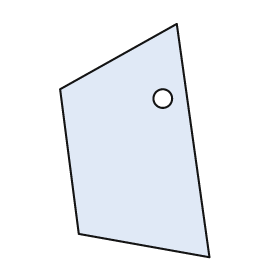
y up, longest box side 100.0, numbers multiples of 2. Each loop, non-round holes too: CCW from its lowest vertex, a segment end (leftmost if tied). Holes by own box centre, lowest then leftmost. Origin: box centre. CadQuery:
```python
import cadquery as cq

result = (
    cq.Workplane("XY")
    .moveTo(32.0, -50.0)
    .lineTo(18.0, 50.0)
    .lineTo(-32.0, 22.0)
    .lineTo(-24.0, -40.0)
    .close()
    .moveTo(12.0, 18.0)
    .circle(4.0)
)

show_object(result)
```